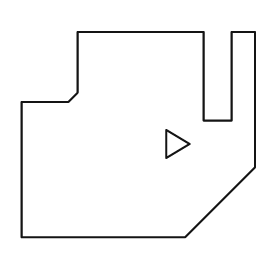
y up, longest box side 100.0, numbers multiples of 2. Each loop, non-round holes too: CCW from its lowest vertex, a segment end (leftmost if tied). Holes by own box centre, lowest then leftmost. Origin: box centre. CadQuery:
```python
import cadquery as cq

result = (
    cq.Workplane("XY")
    .moveTo(-50.0, -44.0)
    .lineTo(20.0, -44.0)
    .lineTo(50.0, -14.0)
    .lineTo(50.0, 44.0)
    .lineTo(40.0, 44.0)
    .lineTo(40.0, 6.0)
    .lineTo(28.0, 6.0)
    .lineTo(28.0, 44.0)
    .lineTo(-26.0, 44.0)
    .lineTo(-26.0, 18.0)
    .lineTo(-30.0, 14.0)
    .lineTo(-50.0, 14.0)
    .close()
    .moveTo(12.0, -10.0)
    .lineTo(22.0, -4.0)
    .lineTo(12.0, 2.0)
    .close()
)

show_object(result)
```